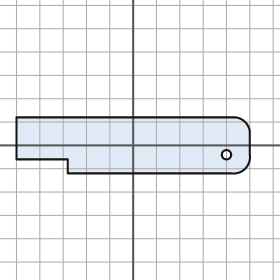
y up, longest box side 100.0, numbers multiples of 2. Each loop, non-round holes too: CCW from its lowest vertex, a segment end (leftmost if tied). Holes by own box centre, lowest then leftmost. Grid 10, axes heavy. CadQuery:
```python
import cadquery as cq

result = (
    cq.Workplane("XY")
    .moveTo(-28.0, -12.0)
    .lineTo(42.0, -12.0)
    .threePointArc((48.0, -10.0), (50.0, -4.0))
    .lineTo(50.0, 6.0)
    .threePointArc((48.0, 10.0), (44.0, 12.0))
    .lineTo(-50.0, 12.0)
    .lineTo(-50.0, -6.0)
    .lineTo(-28.0, -6.0)
    .close()
    .moveTo(40.0, -4.0)
    .circle(2.0)
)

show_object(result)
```